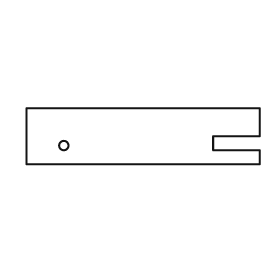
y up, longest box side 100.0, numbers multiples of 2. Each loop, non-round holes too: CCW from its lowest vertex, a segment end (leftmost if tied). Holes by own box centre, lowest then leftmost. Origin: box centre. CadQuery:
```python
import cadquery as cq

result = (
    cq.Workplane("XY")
    .moveTo(-50.0, -12.0)
    .lineTo(50.0, -12.0)
    .lineTo(50.0, -6.0)
    .lineTo(30.0, -6.0)
    .lineTo(30.0, 0.0)
    .lineTo(50.0, 0.0)
    .lineTo(50.0, 12.0)
    .lineTo(-50.0, 12.0)
    .close()
    .moveTo(-34.0, -4.0)
    .circle(2.0)
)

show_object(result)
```